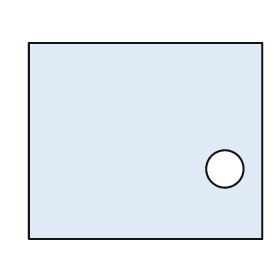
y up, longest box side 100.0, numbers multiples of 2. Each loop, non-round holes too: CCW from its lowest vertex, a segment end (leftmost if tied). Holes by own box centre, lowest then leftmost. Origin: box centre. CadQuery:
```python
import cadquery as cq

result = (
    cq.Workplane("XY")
    .moveTo(-50.0, -42.0)
    .lineTo(50.0, -42.0)
    .lineTo(50.0, 42.0)
    .lineTo(-50.0, 42.0)
    .close()
    .moveTo(34.0, -12.0)
    .circle(8.0)
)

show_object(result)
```